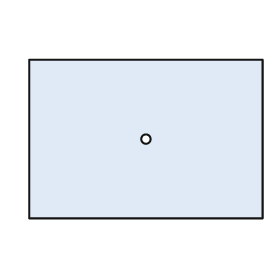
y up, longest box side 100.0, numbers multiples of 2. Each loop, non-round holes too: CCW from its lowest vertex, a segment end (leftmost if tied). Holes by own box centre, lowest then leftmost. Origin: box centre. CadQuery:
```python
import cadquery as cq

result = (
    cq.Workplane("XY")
    .moveTo(-50.0, -34.0)
    .lineTo(50.0, -34.0)
    .lineTo(50.0, 34.0)
    .lineTo(-50.0, 34.0)
    .close()
    .moveTo(0.0, 0.0)
    .circle(2.0)
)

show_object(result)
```